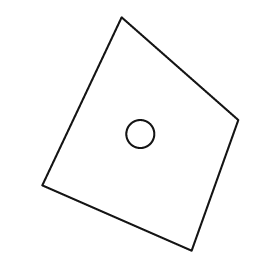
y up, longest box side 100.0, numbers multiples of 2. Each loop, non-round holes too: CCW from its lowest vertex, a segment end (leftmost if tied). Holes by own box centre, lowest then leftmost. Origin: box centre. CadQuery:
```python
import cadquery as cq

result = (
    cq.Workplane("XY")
    .moveTo(22.0, -50.0)
    .lineTo(42.0, 6.0)
    .lineTo(-8.0, 50.0)
    .lineTo(-42.0, -22.0)
    .close()
    .moveTo(0.0, 0.0)
    .circle(6.0)
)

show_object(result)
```